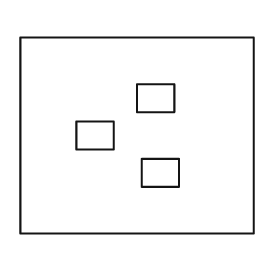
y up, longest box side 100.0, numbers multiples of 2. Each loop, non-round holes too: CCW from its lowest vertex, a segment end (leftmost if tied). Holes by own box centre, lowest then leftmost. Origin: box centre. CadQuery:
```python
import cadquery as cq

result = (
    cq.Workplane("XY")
    .moveTo(-50.0, -42.0)
    .lineTo(50.0, -42.0)
    .lineTo(50.0, 42.0)
    .lineTo(-50.0, 42.0)
    .close()
    .moveTo(2.0, -22.0)
    .lineTo(18.0, -22.0)
    .lineTo(18.0, -10.0)
    .lineTo(2.0, -10.0)
    .close()
    .moveTo(-26.0, -6.0)
    .lineTo(-10.0, -6.0)
    .lineTo(-10.0, 6.0)
    .lineTo(-26.0, 6.0)
    .close()
    .moveTo(0.0, 10.0)
    .lineTo(16.0, 10.0)
    .lineTo(16.0, 22.0)
    .lineTo(0.0, 22.0)
    .close()
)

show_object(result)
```